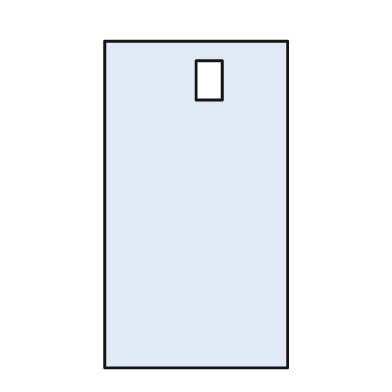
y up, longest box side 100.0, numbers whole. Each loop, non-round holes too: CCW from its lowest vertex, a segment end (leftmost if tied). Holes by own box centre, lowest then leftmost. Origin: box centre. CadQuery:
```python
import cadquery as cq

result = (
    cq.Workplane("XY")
    .moveTo(-28.0, -50.0)
    .lineTo(28.0, -50.0)
    .lineTo(28.0, 50.0)
    .lineTo(-28.0, 50.0)
    .close()
    .moveTo(0.0, 32.0)
    .lineTo(8.0, 32.0)
    .lineTo(8.0, 44.0)
    .lineTo(0.0, 44.0)
    .close()
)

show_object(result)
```